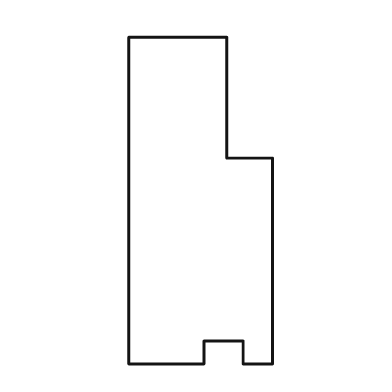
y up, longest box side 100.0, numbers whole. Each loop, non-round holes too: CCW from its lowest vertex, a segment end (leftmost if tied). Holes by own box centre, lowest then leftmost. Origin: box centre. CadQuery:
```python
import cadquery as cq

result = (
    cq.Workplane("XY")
    .moveTo(-22.0, -50.0)
    .lineTo(1.0, -50.0)
    .lineTo(1.0, -43.0)
    .lineTo(13.0, -43.0)
    .lineTo(13.0, -50.0)
    .lineTo(22.0, -50.0)
    .lineTo(22.0, 13.0)
    .lineTo(8.0, 13.0)
    .lineTo(8.0, 50.0)
    .lineTo(-22.0, 50.0)
    .close()
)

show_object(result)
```